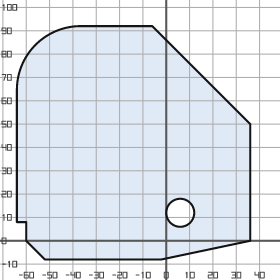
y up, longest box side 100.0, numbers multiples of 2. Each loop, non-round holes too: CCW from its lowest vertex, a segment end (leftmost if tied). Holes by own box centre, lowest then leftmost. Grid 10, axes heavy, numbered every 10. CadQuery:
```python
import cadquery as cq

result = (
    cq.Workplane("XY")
    .moveTo(-52.0, -8.0)
    .lineTo(-2.0, -8.0)
    .lineTo(36.0, 0.0)
    .lineTo(36.0, 50.0)
    .lineTo(-6.0, 92.0)
    .lineTo(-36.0, 92.0)
    .threePointArc((-56.0, 84.0), (-64.0, 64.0))
    .lineTo(-64.0, 8.0)
    .lineTo(-60.0, 8.0)
    .lineTo(-60.0, 0.0)
    .close()
    .moveTo(6.0, 12.0)
    .circle(6.0)
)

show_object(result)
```